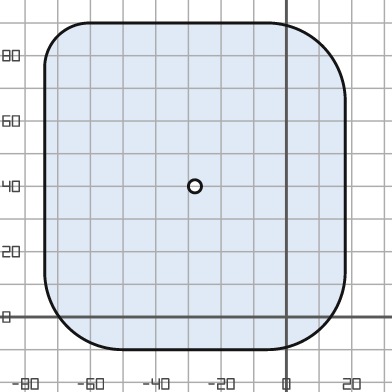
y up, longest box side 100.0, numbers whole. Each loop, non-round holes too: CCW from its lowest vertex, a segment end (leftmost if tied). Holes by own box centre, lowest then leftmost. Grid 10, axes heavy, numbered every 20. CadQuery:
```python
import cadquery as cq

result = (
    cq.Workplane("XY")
    .moveTo(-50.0, -10.0)
    .lineTo(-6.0, -10.0)
    .threePointArc((11.0, -3.0), (18.0, 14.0))
    .lineTo(18.0, 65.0)
    .threePointArc((11.0, 83.0), (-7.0, 90.0))
    .lineTo(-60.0, 90.0)
    .threePointArc((-70.0, 86.0), (-74.0, 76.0))
    .lineTo(-74.0, 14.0)
    .threePointArc((-67.0, -3.0), (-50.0, -10.0))
    .close()
    .moveTo(-28.0, 40.0)
    .circle(2.0)
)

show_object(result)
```